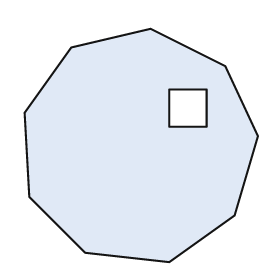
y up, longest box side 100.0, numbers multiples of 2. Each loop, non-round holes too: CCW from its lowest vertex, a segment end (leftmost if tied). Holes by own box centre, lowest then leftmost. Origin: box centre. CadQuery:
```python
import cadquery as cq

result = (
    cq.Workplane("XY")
    .moveTo(12.0, -50.0)
    .lineTo(40.0, -30.0)
    .lineTo(50.0, 4.0)
    .lineTo(36.0, 34.0)
    .lineTo(4.0, 50.0)
    .lineTo(-30.0, 42.0)
    .lineTo(-50.0, 14.0)
    .lineTo(-48.0, -22.0)
    .lineTo(-24.0, -46.0)
    .close()
    .moveTo(12.0, 8.0)
    .lineTo(28.0, 8.0)
    .lineTo(28.0, 24.0)
    .lineTo(12.0, 24.0)
    .close()
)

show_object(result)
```